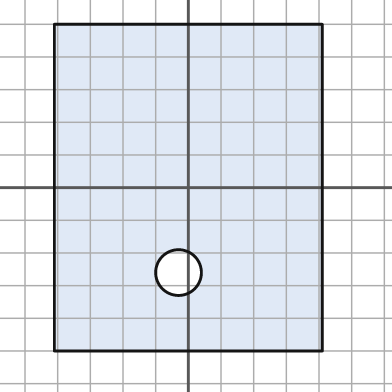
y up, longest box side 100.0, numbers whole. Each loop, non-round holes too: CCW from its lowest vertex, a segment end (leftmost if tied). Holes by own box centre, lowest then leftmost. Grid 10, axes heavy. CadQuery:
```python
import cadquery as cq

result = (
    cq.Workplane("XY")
    .moveTo(-41.0, -50.0)
    .lineTo(41.0, -50.0)
    .lineTo(41.0, 50.0)
    .lineTo(-41.0, 50.0)
    .close()
    .moveTo(-3.0, -26.0)
    .circle(7.0)
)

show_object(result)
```